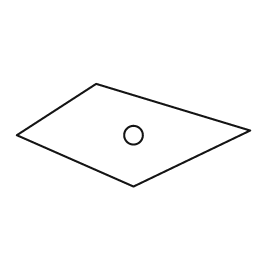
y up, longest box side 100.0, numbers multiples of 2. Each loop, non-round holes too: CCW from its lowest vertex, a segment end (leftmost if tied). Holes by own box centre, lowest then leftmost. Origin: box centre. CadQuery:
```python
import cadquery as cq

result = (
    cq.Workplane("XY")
    .moveTo(0.0, -22.0)
    .lineTo(50.0, 2.0)
    .lineTo(-16.0, 22.0)
    .lineTo(-50.0, 0.0)
    .close()
    .moveTo(0.0, 0.0)
    .circle(4.0)
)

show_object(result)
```